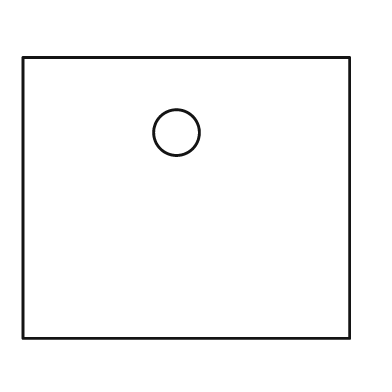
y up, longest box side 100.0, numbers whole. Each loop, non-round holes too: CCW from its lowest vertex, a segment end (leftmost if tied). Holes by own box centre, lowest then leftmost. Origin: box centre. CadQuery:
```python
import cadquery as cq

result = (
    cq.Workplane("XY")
    .moveTo(-50.0, -43.0)
    .lineTo(50.0, -43.0)
    .lineTo(50.0, 43.0)
    .lineTo(-50.0, 43.0)
    .close()
    .moveTo(-3.0, 20.0)
    .circle(7.0)
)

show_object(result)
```